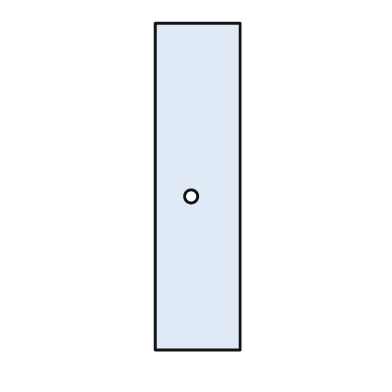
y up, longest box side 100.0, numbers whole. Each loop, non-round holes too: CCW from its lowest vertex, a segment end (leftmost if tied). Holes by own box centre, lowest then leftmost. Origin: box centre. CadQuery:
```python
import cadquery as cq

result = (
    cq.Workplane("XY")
    .moveTo(-13.0, -50.0)
    .lineTo(13.0, -50.0)
    .lineTo(13.0, 50.0)
    .lineTo(-13.0, 50.0)
    .close()
    .moveTo(-2.0, -3.0)
    .circle(2.0)
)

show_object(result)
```